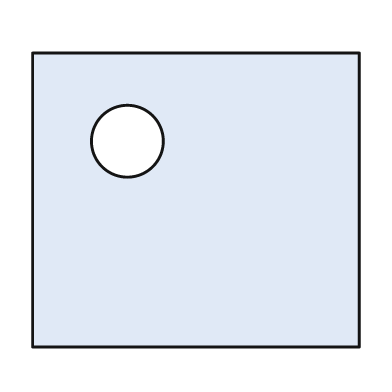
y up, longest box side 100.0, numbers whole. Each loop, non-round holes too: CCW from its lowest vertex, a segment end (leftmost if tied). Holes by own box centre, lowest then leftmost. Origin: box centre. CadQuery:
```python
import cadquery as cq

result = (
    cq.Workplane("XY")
    .moveTo(-50.0, -45.0)
    .lineTo(50.0, -45.0)
    .lineTo(50.0, 45.0)
    .lineTo(-50.0, 45.0)
    .close()
    .moveTo(-21.0, 18.0)
    .circle(11.0)
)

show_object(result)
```